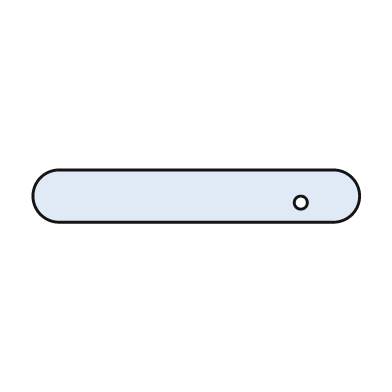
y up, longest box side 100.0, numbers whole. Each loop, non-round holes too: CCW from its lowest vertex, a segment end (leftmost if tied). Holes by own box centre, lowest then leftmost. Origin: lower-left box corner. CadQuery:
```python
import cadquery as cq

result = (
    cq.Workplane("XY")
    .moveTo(8.0, 0.0)
    .lineTo(92.0, 0.0)
    .threePointArc((100.0, 8.0), (92.0, 16.0))
    .lineTo(8.0, 16.0)
    .threePointArc((0.0, 8.0), (8.0, 0.0))
    .close()
    .moveTo(82.0, 6.0)
    .circle(2.0)
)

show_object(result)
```